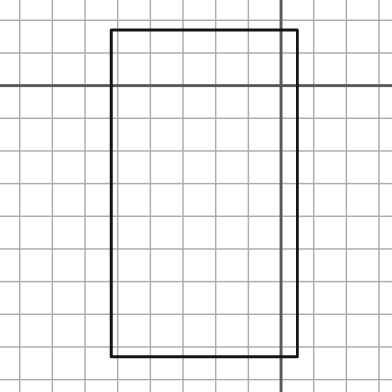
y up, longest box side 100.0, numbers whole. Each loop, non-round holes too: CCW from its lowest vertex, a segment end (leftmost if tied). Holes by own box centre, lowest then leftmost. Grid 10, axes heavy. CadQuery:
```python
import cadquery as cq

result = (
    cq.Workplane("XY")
    .moveTo(-52.0, -83.0)
    .lineTo(5.0, -83.0)
    .lineTo(5.0, 17.0)
    .lineTo(-52.0, 17.0)
    .close()
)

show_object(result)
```